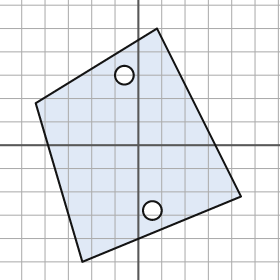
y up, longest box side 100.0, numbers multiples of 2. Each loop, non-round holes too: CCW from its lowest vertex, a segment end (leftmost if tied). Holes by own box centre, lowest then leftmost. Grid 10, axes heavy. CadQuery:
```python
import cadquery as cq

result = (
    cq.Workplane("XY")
    .moveTo(-24.0, -50.0)
    .lineTo(44.0, -22.0)
    .lineTo(8.0, 50.0)
    .lineTo(-44.0, 18.0)
    .close()
    .moveTo(6.0, -28.0)
    .circle(4.0)
    .moveTo(-6.0, 30.0)
    .circle(4.0)
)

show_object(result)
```